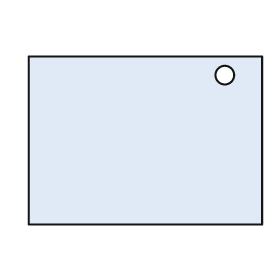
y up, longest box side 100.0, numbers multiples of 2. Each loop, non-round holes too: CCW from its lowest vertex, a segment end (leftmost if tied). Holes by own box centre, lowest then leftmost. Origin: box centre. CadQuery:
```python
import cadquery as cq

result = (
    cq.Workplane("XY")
    .moveTo(-50.0, -36.0)
    .lineTo(50.0, -36.0)
    .lineTo(50.0, 36.0)
    .lineTo(-50.0, 36.0)
    .close()
    .moveTo(34.0, 28.0)
    .circle(4.0)
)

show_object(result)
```